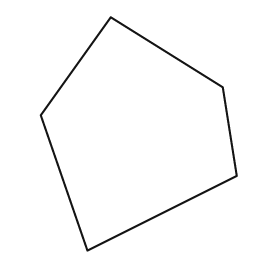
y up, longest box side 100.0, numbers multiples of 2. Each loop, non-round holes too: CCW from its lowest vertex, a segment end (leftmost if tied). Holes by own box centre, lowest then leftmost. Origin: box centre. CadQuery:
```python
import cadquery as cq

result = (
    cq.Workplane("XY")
    .moveTo(-22.0, -50.0)
    .lineTo(42.0, -18.0)
    .lineTo(36.0, 20.0)
    .lineTo(-12.0, 50.0)
    .lineTo(-42.0, 8.0)
    .close()
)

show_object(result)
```